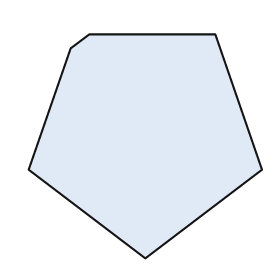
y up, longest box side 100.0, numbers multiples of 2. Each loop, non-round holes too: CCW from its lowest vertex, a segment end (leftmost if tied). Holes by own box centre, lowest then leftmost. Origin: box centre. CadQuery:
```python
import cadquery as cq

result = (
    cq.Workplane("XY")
    .moveTo(0.0, -48.0)
    .lineTo(50.0, -10.0)
    .lineTo(30.0, 48.0)
    .lineTo(-24.0, 48.0)
    .lineTo(-32.0, 42.0)
    .lineTo(-50.0, -10.0)
    .close()
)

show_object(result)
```